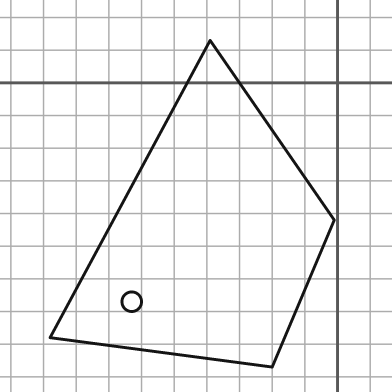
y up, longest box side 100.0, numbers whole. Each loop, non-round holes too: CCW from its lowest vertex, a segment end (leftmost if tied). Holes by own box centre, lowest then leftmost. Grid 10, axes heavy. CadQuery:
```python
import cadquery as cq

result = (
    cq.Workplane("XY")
    .moveTo(-20.0, -87.0)
    .lineTo(-1.0, -42.0)
    .lineTo(-39.0, 13.0)
    .lineTo(-88.0, -78.0)
    .close()
    .moveTo(-63.0, -67.0)
    .circle(3.0)
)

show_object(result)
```